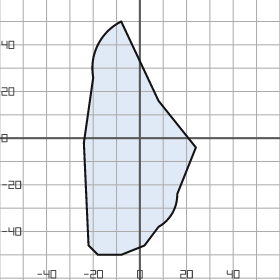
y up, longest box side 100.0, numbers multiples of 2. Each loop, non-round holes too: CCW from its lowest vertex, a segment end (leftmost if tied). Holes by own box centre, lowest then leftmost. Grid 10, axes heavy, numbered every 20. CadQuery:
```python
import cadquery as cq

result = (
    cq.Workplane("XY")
    .moveTo(-18.0, -50.0)
    .lineTo(-8.0, -50.0)
    .lineTo(2.0, -46.0)
    .lineTo(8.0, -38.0)
    .threePointArc((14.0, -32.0), (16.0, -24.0))
    .lineTo(24.0, -4.0)
    .lineTo(8.0, 16.0)
    .lineTo(-8.0, 50.0)
    .threePointArc((-18.0, 40.0), (-20.0, 26.0))
    .lineTo(-24.0, -2.0)
    .lineTo(-22.0, -46.0)
    .close()
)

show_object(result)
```